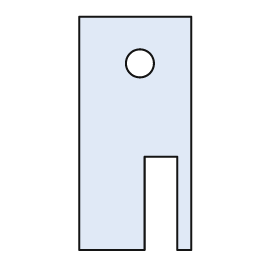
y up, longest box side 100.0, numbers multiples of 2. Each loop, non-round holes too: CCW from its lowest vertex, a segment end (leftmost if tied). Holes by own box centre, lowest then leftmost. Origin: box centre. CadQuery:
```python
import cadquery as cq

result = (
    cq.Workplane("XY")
    .moveTo(-24.0, -50.0)
    .lineTo(4.0, -50.0)
    .lineTo(4.0, -10.0)
    .lineTo(18.0, -10.0)
    .lineTo(18.0, -50.0)
    .lineTo(24.0, -50.0)
    .lineTo(24.0, 50.0)
    .lineTo(-24.0, 50.0)
    .close()
    .moveTo(2.0, 30.0)
    .circle(6.0)
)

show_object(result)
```